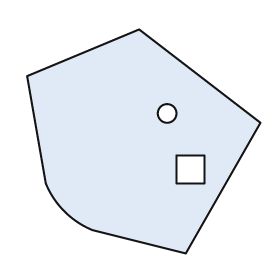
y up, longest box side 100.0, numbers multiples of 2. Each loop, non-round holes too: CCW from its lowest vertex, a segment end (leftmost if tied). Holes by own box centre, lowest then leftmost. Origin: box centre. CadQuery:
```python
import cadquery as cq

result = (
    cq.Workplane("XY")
    .moveTo(18.0, -48.0)
    .lineTo(50.0, 8.0)
    .lineTo(-2.0, 48.0)
    .lineTo(-50.0, 28.0)
    .lineTo(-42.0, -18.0)
    .threePointArc((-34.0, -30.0), (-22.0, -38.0))
    .close()
    .moveTo(14.0, -18.0)
    .lineTo(26.0, -18.0)
    .lineTo(26.0, -6.0)
    .lineTo(14.0, -6.0)
    .close()
    .moveTo(10.0, 12.0)
    .circle(4.0)
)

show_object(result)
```